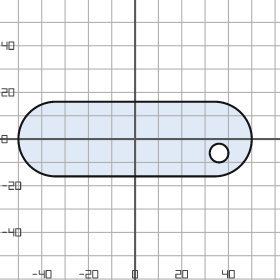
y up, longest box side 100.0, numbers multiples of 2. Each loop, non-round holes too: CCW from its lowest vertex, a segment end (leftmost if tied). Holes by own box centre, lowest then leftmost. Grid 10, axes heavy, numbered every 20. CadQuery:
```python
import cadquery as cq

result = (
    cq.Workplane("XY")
    .moveTo(-34.0, -16.0)
    .lineTo(34.0, -16.0)
    .threePointArc((50.0, 0.0), (34.0, 16.0))
    .lineTo(-34.0, 16.0)
    .threePointArc((-50.0, 0.0), (-34.0, -16.0))
    .close()
    .moveTo(36.0, -6.0)
    .circle(4.0)
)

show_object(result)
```